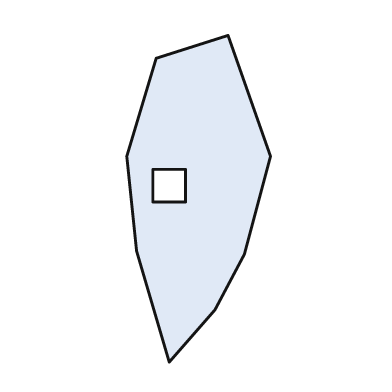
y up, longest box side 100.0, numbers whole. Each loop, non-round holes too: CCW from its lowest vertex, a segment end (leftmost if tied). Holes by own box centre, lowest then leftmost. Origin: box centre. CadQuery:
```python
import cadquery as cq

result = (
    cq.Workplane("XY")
    .moveTo(-9.0, -50.0)
    .lineTo(5.0, -34.0)
    .lineTo(14.0, -17.0)
    .lineTo(22.0, 13.0)
    .lineTo(9.0, 50.0)
    .lineTo(-13.0, 43.0)
    .lineTo(-22.0, 13.0)
    .lineTo(-19.0, -16.0)
    .close()
    .moveTo(-14.0, -1.0)
    .lineTo(-4.0, -1.0)
    .lineTo(-4.0, 9.0)
    .lineTo(-14.0, 9.0)
    .close()
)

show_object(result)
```